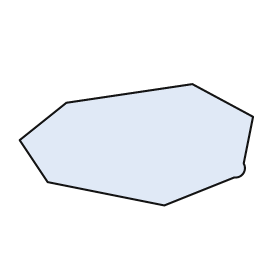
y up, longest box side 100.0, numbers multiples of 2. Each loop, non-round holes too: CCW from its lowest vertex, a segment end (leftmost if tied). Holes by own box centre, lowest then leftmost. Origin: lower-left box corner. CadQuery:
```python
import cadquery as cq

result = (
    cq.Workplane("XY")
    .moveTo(62.0, 0.0)
    .lineTo(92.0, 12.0)
    .threePointArc((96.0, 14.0), (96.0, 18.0))
    .lineTo(100.0, 38.0)
    .lineTo(74.0, 52.0)
    .lineTo(20.0, 44.0)
    .lineTo(0.0, 28.0)
    .lineTo(12.0, 10.0)
    .close()
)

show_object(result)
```